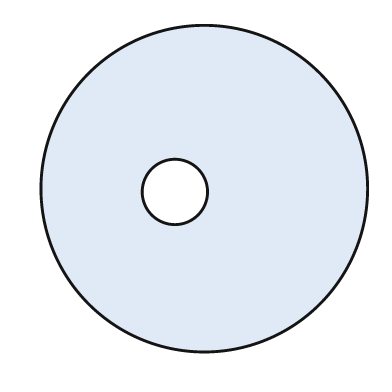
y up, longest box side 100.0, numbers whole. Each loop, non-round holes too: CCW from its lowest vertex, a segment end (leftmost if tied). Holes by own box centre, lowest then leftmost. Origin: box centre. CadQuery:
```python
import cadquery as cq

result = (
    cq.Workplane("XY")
    .moveTo(0.0, 0.0)
    .circle(50.0)
    .moveTo(-9.0, -1.0)
    .circle(10.0)
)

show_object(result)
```